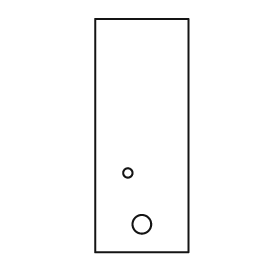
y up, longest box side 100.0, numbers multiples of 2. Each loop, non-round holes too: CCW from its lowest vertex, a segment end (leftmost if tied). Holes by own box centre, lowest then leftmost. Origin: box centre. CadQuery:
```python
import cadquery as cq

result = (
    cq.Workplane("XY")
    .moveTo(-20.0, -50.0)
    .lineTo(20.0, -50.0)
    .lineTo(20.0, 50.0)
    .lineTo(-20.0, 50.0)
    .close()
    .moveTo(0.0, -38.0)
    .circle(4.0)
    .moveTo(-6.0, -16.0)
    .circle(2.0)
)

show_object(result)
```